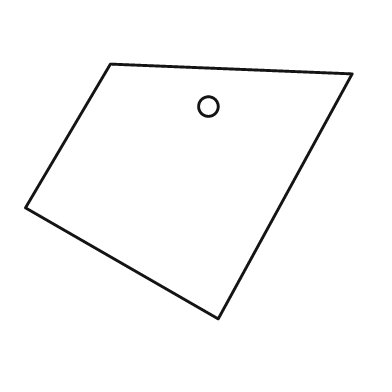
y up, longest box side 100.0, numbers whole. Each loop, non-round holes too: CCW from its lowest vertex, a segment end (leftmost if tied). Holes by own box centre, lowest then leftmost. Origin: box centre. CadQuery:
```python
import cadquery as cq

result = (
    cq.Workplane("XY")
    .moveTo(9.0, -39.0)
    .lineTo(50.0, 36.0)
    .lineTo(-24.0, 39.0)
    .lineTo(-50.0, -5.0)
    .close()
    .moveTo(6.0, 26.0)
    .circle(3.0)
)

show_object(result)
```